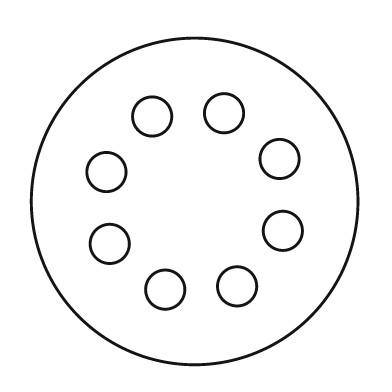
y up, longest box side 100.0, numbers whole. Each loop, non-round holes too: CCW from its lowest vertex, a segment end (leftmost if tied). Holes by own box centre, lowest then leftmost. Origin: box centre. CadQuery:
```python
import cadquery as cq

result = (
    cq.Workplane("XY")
    .moveTo(0.0, 0.0)
    .circle(50.0)
    .moveTo(-9.0, -27.0)
    .circle(6.0)
    .moveTo(13.0, -26.0)
    .circle(6.0)
    .moveTo(-26.0, -13.0)
    .circle(6.0)
    .moveTo(27.0, -9.0)
    .circle(6.0)
    .moveTo(-27.0, 9.0)
    .circle(6.0)
    .moveTo(26.0, 13.0)
    .circle(6.0)
    .moveTo(-13.0, 26.0)
    .circle(6.0)
    .moveTo(9.0, 27.0)
    .circle(6.0)
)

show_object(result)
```